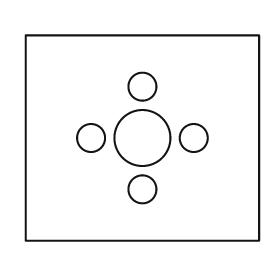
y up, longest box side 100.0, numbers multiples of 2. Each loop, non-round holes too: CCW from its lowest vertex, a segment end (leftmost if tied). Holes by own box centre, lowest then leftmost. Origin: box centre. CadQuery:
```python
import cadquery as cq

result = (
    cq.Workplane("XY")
    .moveTo(-50.0, -44.0)
    .lineTo(50.0, -44.0)
    .lineTo(50.0, 44.0)
    .lineTo(-50.0, 44.0)
    .close()
    .moveTo(0.0, -22.0)
    .circle(6.0)
    .moveTo(-22.0, 0.0)
    .circle(6.0)
    .moveTo(0.0, 0.0)
    .circle(12.0)
    .moveTo(22.0, 0.0)
    .circle(6.0)
    .moveTo(0.0, 22.0)
    .circle(6.0)
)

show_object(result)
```